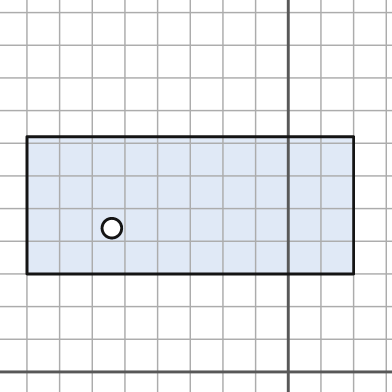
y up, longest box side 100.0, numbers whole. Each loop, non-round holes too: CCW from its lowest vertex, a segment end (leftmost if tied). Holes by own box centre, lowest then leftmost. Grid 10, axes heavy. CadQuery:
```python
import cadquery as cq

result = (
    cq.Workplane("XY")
    .moveTo(-80.0, 30.0)
    .lineTo(20.0, 30.0)
    .lineTo(20.0, 72.0)
    .lineTo(-80.0, 72.0)
    .close()
    .moveTo(-54.0, 44.0)
    .circle(3.0)
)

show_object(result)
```